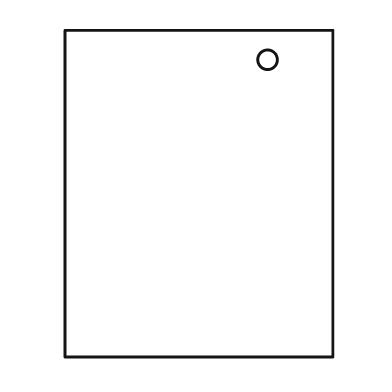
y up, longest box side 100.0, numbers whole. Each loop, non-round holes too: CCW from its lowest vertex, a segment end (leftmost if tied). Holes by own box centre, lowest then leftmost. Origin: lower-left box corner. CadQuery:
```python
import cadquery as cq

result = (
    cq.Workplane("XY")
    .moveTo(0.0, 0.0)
    .lineTo(82.0, 0.0)
    .lineTo(82.0, 100.0)
    .lineTo(0.0, 100.0)
    .close()
    .moveTo(62.0, 91.0)
    .circle(3.0)
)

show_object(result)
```